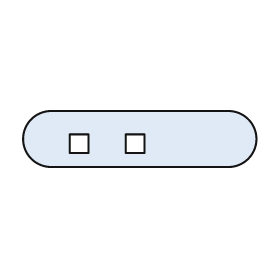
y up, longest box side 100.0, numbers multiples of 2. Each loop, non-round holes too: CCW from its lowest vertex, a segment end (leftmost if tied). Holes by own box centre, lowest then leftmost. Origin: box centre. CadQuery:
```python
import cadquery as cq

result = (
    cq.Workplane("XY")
    .moveTo(-38.0, -12.0)
    .lineTo(38.0, -12.0)
    .threePointArc((50.0, 0.0), (38.0, 12.0))
    .lineTo(-38.0, 12.0)
    .threePointArc((-50.0, 0.0), (-38.0, -12.0))
    .close()
    .moveTo(-30.0, -6.0)
    .lineTo(-22.0, -6.0)
    .lineTo(-22.0, 2.0)
    .lineTo(-30.0, 2.0)
    .close()
    .moveTo(-6.0, -6.0)
    .lineTo(2.0, -6.0)
    .lineTo(2.0, 2.0)
    .lineTo(-6.0, 2.0)
    .close()
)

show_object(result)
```